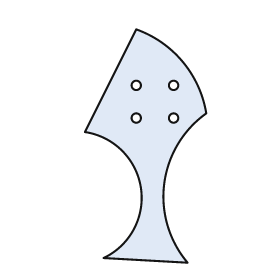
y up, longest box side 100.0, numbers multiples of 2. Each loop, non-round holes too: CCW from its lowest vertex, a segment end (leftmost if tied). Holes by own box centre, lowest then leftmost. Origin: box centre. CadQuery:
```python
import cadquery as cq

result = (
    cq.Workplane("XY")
    .moveTo(18.0, -50.0)
    .threePointArc((8.0, -16.0), (26.0, 14.0))
    .threePointArc((16.0, 36.0), (-4.0, 50.0))
    .lineTo(-26.0, 6.0)
    .threePointArc((-2.0, -18.0), (-18.0, -48.0))
    .close()
    .moveTo(-4.0, 12.0)
    .circle(2.0)
    .moveTo(12.0, 12.0)
    .circle(2.0)
    .moveTo(-4.0, 26.0)
    .circle(2.0)
    .moveTo(12.0, 26.0)
    .circle(2.0)
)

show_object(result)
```